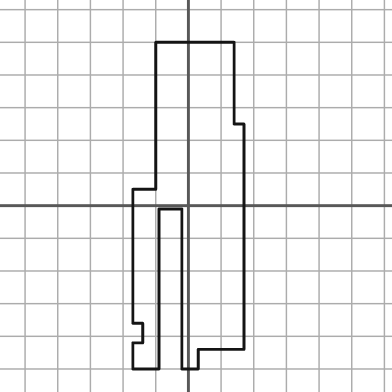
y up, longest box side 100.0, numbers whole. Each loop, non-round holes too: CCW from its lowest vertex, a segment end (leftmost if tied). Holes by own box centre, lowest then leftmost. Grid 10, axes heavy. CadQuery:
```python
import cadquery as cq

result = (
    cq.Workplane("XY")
    .moveTo(-17.0, -50.0)
    .lineTo(-9.0, -50.0)
    .lineTo(-9.0, -1.0)
    .lineTo(-2.0, -1.0)
    .lineTo(-2.0, -50.0)
    .lineTo(3.0, -50.0)
    .lineTo(3.0, -44.0)
    .lineTo(17.0, -44.0)
    .lineTo(17.0, 25.0)
    .lineTo(14.0, 25.0)
    .lineTo(14.0, 50.0)
    .lineTo(-10.0, 50.0)
    .lineTo(-10.0, 5.0)
    .lineTo(-17.0, 5.0)
    .lineTo(-17.0, -36.0)
    .lineTo(-14.0, -36.0)
    .lineTo(-14.0, -42.0)
    .lineTo(-17.0, -42.0)
    .close()
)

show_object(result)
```